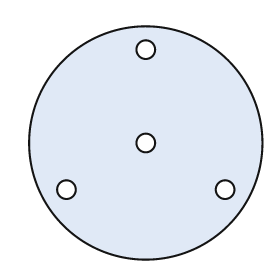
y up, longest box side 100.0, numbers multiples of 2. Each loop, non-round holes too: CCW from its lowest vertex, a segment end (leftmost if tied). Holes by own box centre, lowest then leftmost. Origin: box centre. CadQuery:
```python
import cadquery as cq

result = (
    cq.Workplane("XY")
    .moveTo(0.0, 0.0)
    .circle(50.0)
    .moveTo(-34.0, -20.0)
    .circle(4.0)
    .moveTo(34.0, -20.0)
    .circle(4.0)
    .moveTo(0.0, 0.0)
    .circle(4.0)
    .moveTo(0.0, 40.0)
    .circle(4.0)
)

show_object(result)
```